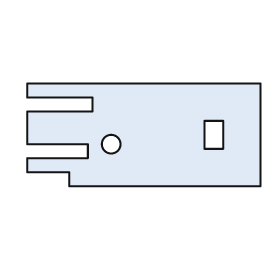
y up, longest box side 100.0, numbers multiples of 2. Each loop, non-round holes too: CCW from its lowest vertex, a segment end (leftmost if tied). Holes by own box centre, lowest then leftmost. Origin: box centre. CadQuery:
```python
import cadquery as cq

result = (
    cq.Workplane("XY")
    .moveTo(-32.0, -22.0)
    .lineTo(50.0, -22.0)
    .lineTo(50.0, 22.0)
    .lineTo(-50.0, 22.0)
    .lineTo(-50.0, 16.0)
    .lineTo(-22.0, 16.0)
    .lineTo(-22.0, 10.0)
    .lineTo(-50.0, 10.0)
    .lineTo(-50.0, -4.0)
    .lineTo(-24.0, -4.0)
    .lineTo(-24.0, -10.0)
    .lineTo(-50.0, -10.0)
    .lineTo(-50.0, -16.0)
    .lineTo(-32.0, -16.0)
    .close()
    .moveTo(-14.0, -4.0)
    .circle(4.0)
    .moveTo(26.0, -6.0)
    .lineTo(34.0, -6.0)
    .lineTo(34.0, 6.0)
    .lineTo(26.0, 6.0)
    .close()
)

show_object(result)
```